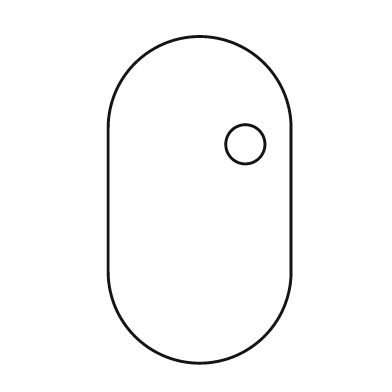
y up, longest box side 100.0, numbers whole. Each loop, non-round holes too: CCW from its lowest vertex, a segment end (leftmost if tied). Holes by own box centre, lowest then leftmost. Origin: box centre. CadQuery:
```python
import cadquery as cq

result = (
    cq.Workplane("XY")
    .moveTo(-28.0, -22.0)
    .threePointArc((0.0, -50.0), (28.0, -22.0))
    .lineTo(28.0, 22.0)
    .threePointArc((0.0, 50.0), (-28.0, 22.0))
    .close()
    .moveTo(14.0, 17.0)
    .circle(6.0)
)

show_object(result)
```